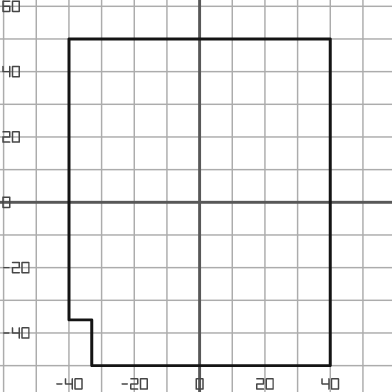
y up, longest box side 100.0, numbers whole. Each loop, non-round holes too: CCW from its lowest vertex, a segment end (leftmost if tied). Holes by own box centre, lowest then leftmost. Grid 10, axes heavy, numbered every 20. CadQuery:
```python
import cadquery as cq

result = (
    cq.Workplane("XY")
    .moveTo(-33.0, -50.0)
    .lineTo(40.0, -50.0)
    .lineTo(40.0, 50.0)
    .lineTo(-40.0, 50.0)
    .lineTo(-40.0, -36.0)
    .lineTo(-33.0, -36.0)
    .close()
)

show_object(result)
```